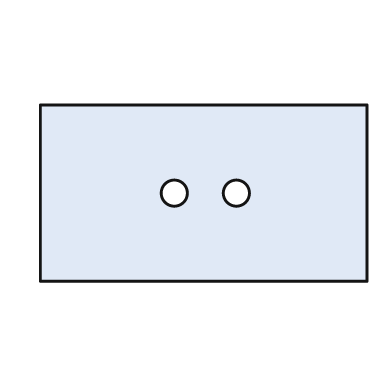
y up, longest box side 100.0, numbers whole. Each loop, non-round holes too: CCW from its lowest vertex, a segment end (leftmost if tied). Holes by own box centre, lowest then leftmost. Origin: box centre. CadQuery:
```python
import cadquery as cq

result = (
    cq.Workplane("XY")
    .moveTo(-50.0, -27.0)
    .lineTo(50.0, -27.0)
    .lineTo(50.0, 27.0)
    .lineTo(-50.0, 27.0)
    .close()
    .moveTo(-9.0, 0.0)
    .circle(4.0)
    .moveTo(10.0, 0.0)
    .circle(4.0)
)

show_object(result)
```